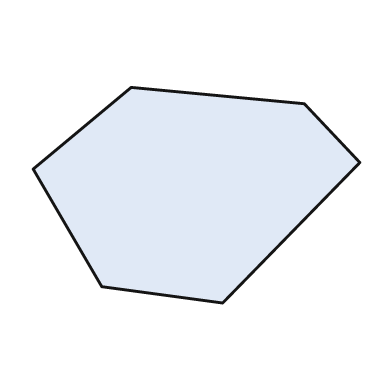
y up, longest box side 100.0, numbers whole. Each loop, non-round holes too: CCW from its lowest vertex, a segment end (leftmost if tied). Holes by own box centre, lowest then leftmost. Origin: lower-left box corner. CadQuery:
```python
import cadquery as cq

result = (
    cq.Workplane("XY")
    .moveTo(58.0, 0.0)
    .lineTo(100.0, 43.0)
    .lineTo(83.0, 61.0)
    .lineTo(30.0, 66.0)
    .lineTo(0.0, 41.0)
    .lineTo(21.0, 5.0)
    .close()
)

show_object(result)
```